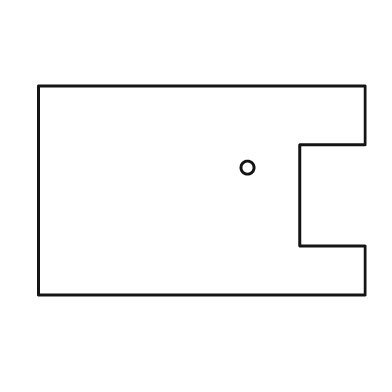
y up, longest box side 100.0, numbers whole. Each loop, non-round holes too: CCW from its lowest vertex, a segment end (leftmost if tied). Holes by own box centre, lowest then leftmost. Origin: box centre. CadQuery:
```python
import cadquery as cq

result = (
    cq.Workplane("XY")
    .moveTo(-50.0, -32.0)
    .lineTo(50.0, -32.0)
    .lineTo(50.0, -17.0)
    .lineTo(30.0, -17.0)
    .lineTo(30.0, 14.0)
    .lineTo(50.0, 14.0)
    .lineTo(50.0, 32.0)
    .lineTo(-50.0, 32.0)
    .close()
    .moveTo(14.0, 7.0)
    .circle(2.0)
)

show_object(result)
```